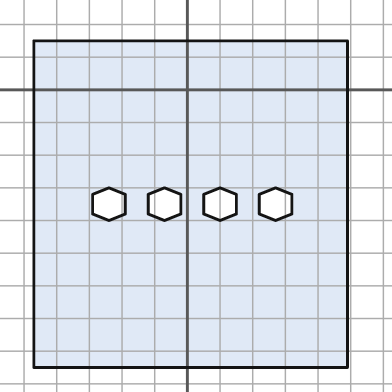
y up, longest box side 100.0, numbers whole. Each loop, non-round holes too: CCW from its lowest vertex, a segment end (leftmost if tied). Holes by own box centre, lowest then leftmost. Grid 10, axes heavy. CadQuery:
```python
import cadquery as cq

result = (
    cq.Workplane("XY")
    .moveTo(-47.0, -85.0)
    .lineTo(49.0, -85.0)
    .lineTo(49.0, 15.0)
    .lineTo(-47.0, 15.0)
    .close()
    .moveTo(-24.0, -40.0)
    .lineTo(-19.0, -38.0)
    .lineTo(-19.0, -32.0)
    .lineTo(-24.0, -30.0)
    .lineTo(-29.0, -32.0)
    .lineTo(-29.0, -38.0)
    .close()
    .moveTo(-7.0, -40.0)
    .lineTo(-2.0, -38.0)
    .lineTo(-2.0, -32.0)
    .lineTo(-7.0, -30.0)
    .lineTo(-12.0, -32.0)
    .lineTo(-12.0, -38.0)
    .close()
    .moveTo(10.0, -40.0)
    .lineTo(15.0, -38.0)
    .lineTo(15.0, -32.0)
    .lineTo(10.0, -30.0)
    .lineTo(5.0, -32.0)
    .lineTo(5.0, -38.0)
    .close()
    .moveTo(27.0, -40.0)
    .lineTo(32.0, -38.0)
    .lineTo(32.0, -32.0)
    .lineTo(27.0, -30.0)
    .lineTo(22.0, -32.0)
    .lineTo(22.0, -38.0)
    .close()
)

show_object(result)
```